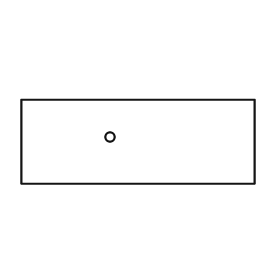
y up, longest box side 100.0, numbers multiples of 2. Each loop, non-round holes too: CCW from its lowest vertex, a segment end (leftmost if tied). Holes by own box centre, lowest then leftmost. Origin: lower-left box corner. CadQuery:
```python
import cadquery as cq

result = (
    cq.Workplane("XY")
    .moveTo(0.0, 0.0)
    .lineTo(100.0, 0.0)
    .lineTo(100.0, 36.0)
    .lineTo(0.0, 36.0)
    .close()
    .moveTo(38.0, 20.0)
    .circle(2.0)
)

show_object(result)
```